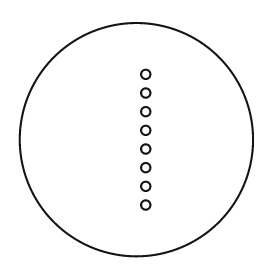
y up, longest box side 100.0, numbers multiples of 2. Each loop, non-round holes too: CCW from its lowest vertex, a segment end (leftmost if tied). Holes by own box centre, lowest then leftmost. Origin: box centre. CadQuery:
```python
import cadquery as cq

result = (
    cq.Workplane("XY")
    .moveTo(0.0, 0.0)
    .circle(50.0)
    .moveTo(4.0, -28.0)
    .circle(2.0)
    .moveTo(4.0, -20.0)
    .circle(2.0)
    .moveTo(4.0, -12.0)
    .circle(2.0)
    .moveTo(4.0, -4.0)
    .circle(2.0)
    .moveTo(4.0, 4.0)
    .circle(2.0)
    .moveTo(4.0, 12.0)
    .circle(2.0)
    .moveTo(4.0, 20.0)
    .circle(2.0)
    .moveTo(4.0, 28.0)
    .circle(2.0)
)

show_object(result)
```